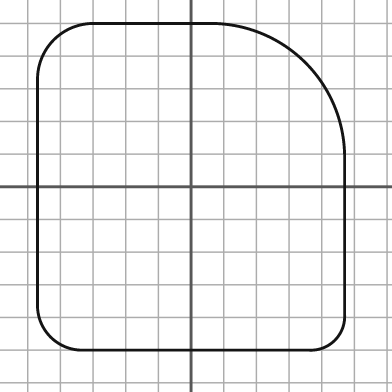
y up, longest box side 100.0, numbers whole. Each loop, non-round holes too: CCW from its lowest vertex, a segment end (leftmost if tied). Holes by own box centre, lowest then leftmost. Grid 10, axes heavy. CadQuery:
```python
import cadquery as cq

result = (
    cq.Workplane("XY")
    .moveTo(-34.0, -50.0)
    .lineTo(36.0, -50.0)
    .threePointArc((44.0, -47.0), (47.0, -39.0))
    .lineTo(47.0, 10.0)
    .threePointArc((35.0, 38.0), (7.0, 50.0))
    .lineTo(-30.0, 50.0)
    .threePointArc((-42.0, 45.0), (-47.0, 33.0))
    .lineTo(-47.0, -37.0)
    .threePointArc((-43.0, -46.0), (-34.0, -50.0))
    .close()
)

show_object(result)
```